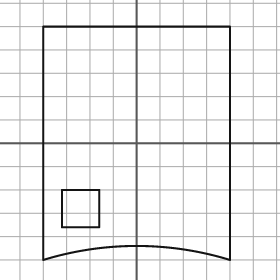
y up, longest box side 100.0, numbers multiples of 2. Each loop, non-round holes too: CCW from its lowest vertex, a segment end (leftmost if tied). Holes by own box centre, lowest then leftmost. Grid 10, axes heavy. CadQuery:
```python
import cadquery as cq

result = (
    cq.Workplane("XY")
    .moveTo(-40.0, -50.0)
    .threePointArc((0.0, -44.0), (40.0, -50.0))
    .lineTo(40.0, 50.0)
    .lineTo(-40.0, 50.0)
    .close()
    .moveTo(-32.0, -36.0)
    .lineTo(-16.0, -36.0)
    .lineTo(-16.0, -20.0)
    .lineTo(-32.0, -20.0)
    .close()
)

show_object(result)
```